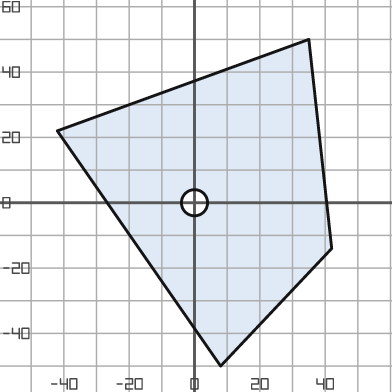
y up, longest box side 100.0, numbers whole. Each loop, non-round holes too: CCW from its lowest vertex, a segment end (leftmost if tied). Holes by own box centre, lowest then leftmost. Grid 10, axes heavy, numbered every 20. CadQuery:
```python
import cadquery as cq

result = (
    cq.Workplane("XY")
    .moveTo(8.0, -50.0)
    .lineTo(42.0, -14.0)
    .lineTo(35.0, 50.0)
    .lineTo(-42.0, 22.0)
    .close()
    .moveTo(0.0, 0.0)
    .circle(4.0)
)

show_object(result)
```